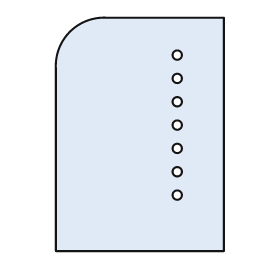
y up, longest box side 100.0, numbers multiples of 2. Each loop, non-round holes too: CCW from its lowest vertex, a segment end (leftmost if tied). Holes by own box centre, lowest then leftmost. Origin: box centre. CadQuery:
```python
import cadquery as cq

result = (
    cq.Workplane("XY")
    .moveTo(-36.0, -50.0)
    .lineTo(36.0, -50.0)
    .lineTo(36.0, 50.0)
    .lineTo(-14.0, 50.0)
    .threePointArc((-30.0, 44.0), (-36.0, 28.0))
    .close()
    .moveTo(16.0, -26.0)
    .circle(2.0)
    .moveTo(16.0, -16.0)
    .circle(2.0)
    .moveTo(16.0, -6.0)
    .circle(2.0)
    .moveTo(16.0, 4.0)
    .circle(2.0)
    .moveTo(16.0, 14.0)
    .circle(2.0)
    .moveTo(16.0, 24.0)
    .circle(2.0)
    .moveTo(16.0, 34.0)
    .circle(2.0)
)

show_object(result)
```